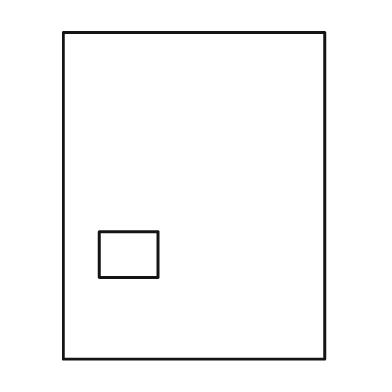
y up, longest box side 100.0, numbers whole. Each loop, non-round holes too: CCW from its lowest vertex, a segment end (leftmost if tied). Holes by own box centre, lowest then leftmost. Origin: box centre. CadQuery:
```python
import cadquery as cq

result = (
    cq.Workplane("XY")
    .moveTo(-40.0, -50.0)
    .lineTo(40.0, -50.0)
    .lineTo(40.0, 50.0)
    .lineTo(-40.0, 50.0)
    .close()
    .moveTo(-29.0, -25.0)
    .lineTo(-11.0, -25.0)
    .lineTo(-11.0, -11.0)
    .lineTo(-29.0, -11.0)
    .close()
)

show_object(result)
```